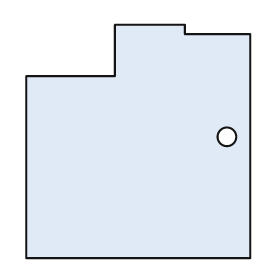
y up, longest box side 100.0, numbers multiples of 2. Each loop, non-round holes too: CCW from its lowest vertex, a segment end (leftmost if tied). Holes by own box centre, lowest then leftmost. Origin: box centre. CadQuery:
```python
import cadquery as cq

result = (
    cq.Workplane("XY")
    .moveTo(-48.0, -50.0)
    .lineTo(48.0, -50.0)
    .lineTo(48.0, 46.0)
    .lineTo(20.0, 46.0)
    .lineTo(20.0, 50.0)
    .lineTo(-10.0, 50.0)
    .lineTo(-10.0, 28.0)
    .lineTo(-48.0, 28.0)
    .close()
    .moveTo(38.0, 2.0)
    .circle(4.0)
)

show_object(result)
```